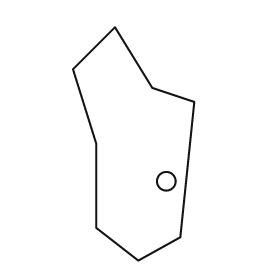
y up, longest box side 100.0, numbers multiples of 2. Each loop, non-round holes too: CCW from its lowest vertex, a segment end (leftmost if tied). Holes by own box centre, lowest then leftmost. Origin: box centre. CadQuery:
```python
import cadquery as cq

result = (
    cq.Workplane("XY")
    .moveTo(2.0, -50.0)
    .lineTo(20.0, -40.0)
    .lineTo(26.0, 18.0)
    .lineTo(8.0, 24.0)
    .lineTo(-8.0, 50.0)
    .lineTo(-26.0, 32.0)
    .lineTo(-16.0, 0.0)
    .lineTo(-16.0, -36.0)
    .close()
    .moveTo(14.0, -16.0)
    .circle(4.0)
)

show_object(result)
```